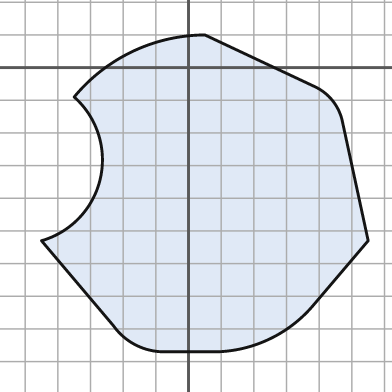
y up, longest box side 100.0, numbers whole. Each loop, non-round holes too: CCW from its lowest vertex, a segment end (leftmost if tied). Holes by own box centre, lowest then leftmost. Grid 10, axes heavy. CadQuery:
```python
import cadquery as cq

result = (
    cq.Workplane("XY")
    .moveTo(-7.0, -87.0)
    .lineTo(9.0, -87.0)
    .threePointArc((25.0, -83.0), (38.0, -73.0))
    .lineTo(55.0, -53.0)
    .lineTo(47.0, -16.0)
    .threePointArc((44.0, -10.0), (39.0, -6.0))
    .lineTo(5.0, 10.0)
    .threePointArc((-17.0, 5.0), (-35.0, -9.0))
    .threePointArc((-27.0, -34.0), (-45.0, -53.0))
    .lineTo(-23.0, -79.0)
    .threePointArc((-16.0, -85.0), (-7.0, -87.0))
    .close()
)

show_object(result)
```